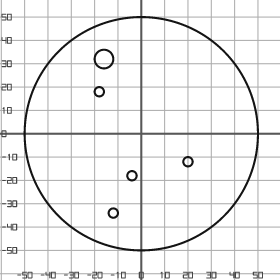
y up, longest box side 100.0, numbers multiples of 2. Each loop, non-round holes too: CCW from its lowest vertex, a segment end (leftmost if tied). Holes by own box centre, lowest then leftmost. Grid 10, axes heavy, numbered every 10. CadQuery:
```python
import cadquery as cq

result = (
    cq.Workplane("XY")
    .moveTo(0.0, 0.0)
    .circle(50.0)
    .moveTo(-12.0, -34.0)
    .circle(2.0)
    .moveTo(-4.0, -18.0)
    .circle(2.0)
    .moveTo(20.0, -12.0)
    .circle(2.0)
    .moveTo(-18.0, 18.0)
    .circle(2.0)
    .moveTo(-16.0, 32.0)
    .circle(4.0)
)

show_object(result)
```